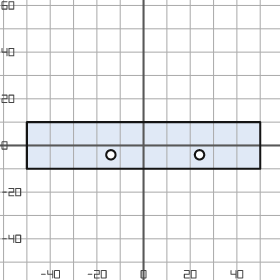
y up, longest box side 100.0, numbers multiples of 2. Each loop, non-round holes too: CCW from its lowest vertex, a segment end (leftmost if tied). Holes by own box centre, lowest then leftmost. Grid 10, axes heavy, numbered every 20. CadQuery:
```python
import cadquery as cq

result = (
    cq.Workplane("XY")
    .moveTo(-50.0, -10.0)
    .lineTo(50.0, -10.0)
    .lineTo(50.0, 10.0)
    .lineTo(-50.0, 10.0)
    .close()
    .moveTo(-14.0, -4.0)
    .circle(2.0)
    .moveTo(24.0, -4.0)
    .circle(2.0)
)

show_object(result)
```